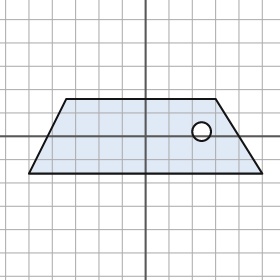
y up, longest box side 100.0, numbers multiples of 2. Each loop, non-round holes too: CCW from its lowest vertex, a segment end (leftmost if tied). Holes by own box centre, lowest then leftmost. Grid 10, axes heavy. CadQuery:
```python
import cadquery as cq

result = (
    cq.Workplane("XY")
    .moveTo(-50.0, -16.0)
    .lineTo(50.0, -16.0)
    .lineTo(30.0, 16.0)
    .lineTo(-34.0, 16.0)
    .close()
    .moveTo(24.0, 2.0)
    .circle(4.0)
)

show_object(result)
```